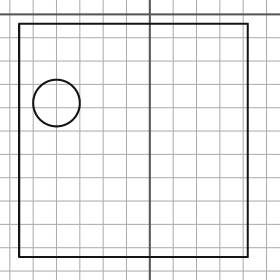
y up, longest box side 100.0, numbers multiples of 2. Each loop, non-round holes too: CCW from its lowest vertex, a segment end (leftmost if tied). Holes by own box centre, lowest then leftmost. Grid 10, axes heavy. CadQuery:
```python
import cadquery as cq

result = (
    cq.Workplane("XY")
    .moveTo(-56.0, -104.0)
    .lineTo(42.0, -104.0)
    .lineTo(42.0, -4.0)
    .lineTo(-56.0, -4.0)
    .close()
    .moveTo(-40.0, -38.0)
    .circle(10.0)
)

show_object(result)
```